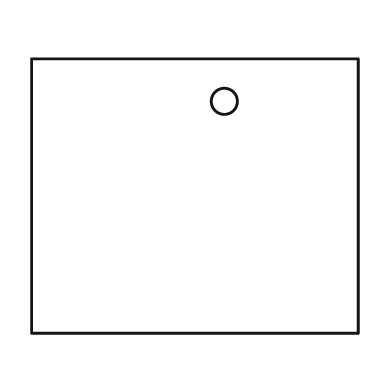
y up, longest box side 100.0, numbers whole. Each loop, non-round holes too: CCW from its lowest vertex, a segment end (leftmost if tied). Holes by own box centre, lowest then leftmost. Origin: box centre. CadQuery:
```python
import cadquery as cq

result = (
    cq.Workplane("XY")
    .moveTo(-50.0, -42.0)
    .lineTo(50.0, -42.0)
    .lineTo(50.0, 42.0)
    .lineTo(-50.0, 42.0)
    .close()
    .moveTo(9.0, 29.0)
    .circle(4.0)
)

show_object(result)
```